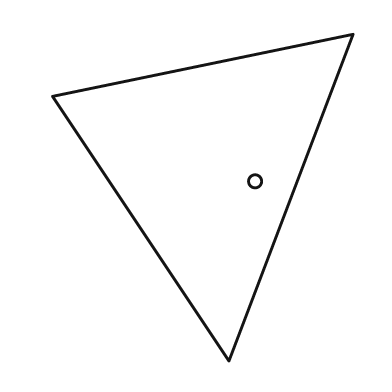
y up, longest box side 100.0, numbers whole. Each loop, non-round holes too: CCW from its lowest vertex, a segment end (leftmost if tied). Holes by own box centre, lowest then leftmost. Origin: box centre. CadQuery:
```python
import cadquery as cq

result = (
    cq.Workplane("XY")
    .moveTo(8.0, -50.0)
    .lineTo(46.0, 50.0)
    .lineTo(-46.0, 31.0)
    .close()
    .moveTo(16.0, 5.0)
    .circle(2.0)
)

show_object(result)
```